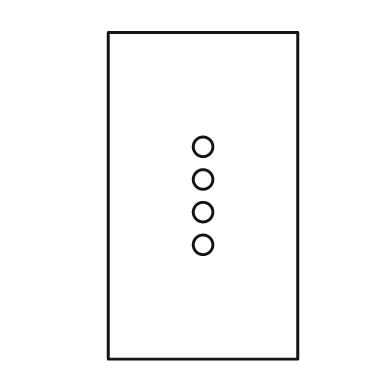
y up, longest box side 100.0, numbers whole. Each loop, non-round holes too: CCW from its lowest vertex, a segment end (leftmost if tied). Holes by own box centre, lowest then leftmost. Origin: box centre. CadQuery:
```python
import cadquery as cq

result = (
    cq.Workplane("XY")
    .moveTo(-29.0, -50.0)
    .lineTo(29.0, -50.0)
    .lineTo(29.0, 50.0)
    .lineTo(-29.0, 50.0)
    .close()
    .moveTo(0.0, -15.0)
    .circle(3.0)
    .moveTo(0.0, -5.0)
    .circle(3.0)
    .moveTo(0.0, 5.0)
    .circle(3.0)
    .moveTo(0.0, 15.0)
    .circle(3.0)
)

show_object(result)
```